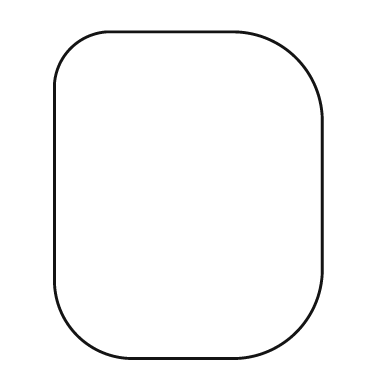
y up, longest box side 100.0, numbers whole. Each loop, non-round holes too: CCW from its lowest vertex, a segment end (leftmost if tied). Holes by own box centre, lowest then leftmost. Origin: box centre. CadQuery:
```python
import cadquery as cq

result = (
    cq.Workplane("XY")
    .moveTo(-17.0, -50.0)
    .lineTo(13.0, -50.0)
    .threePointArc((33.0, -42.0), (41.0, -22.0))
    .lineTo(41.0, 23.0)
    .threePointArc((33.0, 42.0), (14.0, 50.0))
    .lineTo(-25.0, 50.0)
    .threePointArc((-36.0, 45.0), (-41.0, 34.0))
    .lineTo(-41.0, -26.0)
    .threePointArc((-34.0, -43.0), (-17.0, -50.0))
    .close()
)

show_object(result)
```